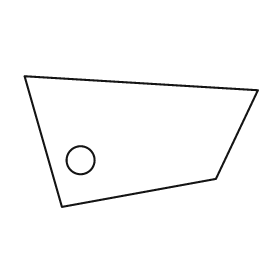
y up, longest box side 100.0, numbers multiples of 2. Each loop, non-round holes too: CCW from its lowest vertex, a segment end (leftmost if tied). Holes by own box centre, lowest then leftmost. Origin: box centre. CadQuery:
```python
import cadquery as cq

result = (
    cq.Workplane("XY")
    .moveTo(-34.0, -28.0)
    .lineTo(32.0, -16.0)
    .lineTo(50.0, 22.0)
    .lineTo(-50.0, 28.0)
    .close()
    .moveTo(-26.0, -8.0)
    .circle(6.0)
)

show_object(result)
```